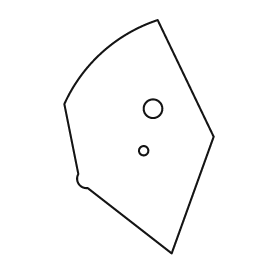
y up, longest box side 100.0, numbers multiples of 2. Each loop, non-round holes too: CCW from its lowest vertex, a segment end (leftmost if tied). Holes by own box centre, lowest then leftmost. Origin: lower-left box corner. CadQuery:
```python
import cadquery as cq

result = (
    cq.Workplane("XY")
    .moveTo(46.0, 0.0)
    .lineTo(64.0, 50.0)
    .lineTo(40.0, 100.0)
    .threePointArc((16.0, 86.0), (0.0, 64.0))
    .lineTo(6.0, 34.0)
    .threePointArc((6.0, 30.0), (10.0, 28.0))
    .close()
    .moveTo(34.0, 44.0)
    .circle(2.0)
    .moveTo(38.0, 62.0)
    .circle(4.0)
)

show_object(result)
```